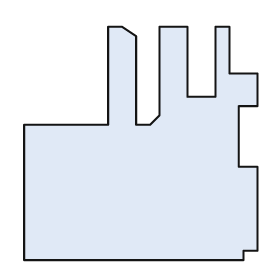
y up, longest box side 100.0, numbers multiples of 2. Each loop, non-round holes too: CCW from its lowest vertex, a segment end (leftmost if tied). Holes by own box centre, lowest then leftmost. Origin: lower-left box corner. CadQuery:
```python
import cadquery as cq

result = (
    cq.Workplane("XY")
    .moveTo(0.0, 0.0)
    .lineTo(94.0, 0.0)
    .lineTo(94.0, 4.0)
    .lineTo(100.0, 4.0)
    .lineTo(100.0, 40.0)
    .lineTo(92.0, 40.0)
    .lineTo(92.0, 66.0)
    .lineTo(100.0, 66.0)
    .lineTo(100.0, 80.0)
    .lineTo(88.0, 80.0)
    .lineTo(88.0, 100.0)
    .lineTo(82.0, 100.0)
    .lineTo(82.0, 70.0)
    .lineTo(70.0, 70.0)
    .lineTo(70.0, 100.0)
    .lineTo(58.0, 100.0)
    .lineTo(58.0, 62.0)
    .lineTo(54.0, 58.0)
    .lineTo(48.0, 58.0)
    .lineTo(48.0, 96.0)
    .lineTo(42.0, 100.0)
    .lineTo(36.0, 100.0)
    .lineTo(36.0, 58.0)
    .lineTo(0.0, 58.0)
    .close()
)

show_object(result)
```